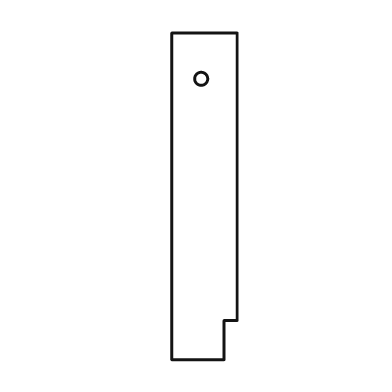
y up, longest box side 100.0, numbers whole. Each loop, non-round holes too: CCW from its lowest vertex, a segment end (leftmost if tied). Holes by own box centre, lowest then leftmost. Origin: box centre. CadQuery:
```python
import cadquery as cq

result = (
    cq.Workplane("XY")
    .moveTo(-10.0, -50.0)
    .lineTo(6.0, -50.0)
    .lineTo(6.0, -38.0)
    .lineTo(10.0, -38.0)
    .lineTo(10.0, 50.0)
    .lineTo(-10.0, 50.0)
    .close()
    .moveTo(-1.0, 36.0)
    .circle(2.0)
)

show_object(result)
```